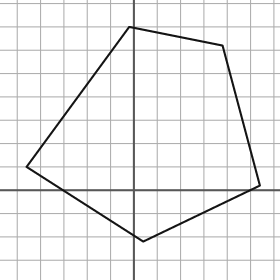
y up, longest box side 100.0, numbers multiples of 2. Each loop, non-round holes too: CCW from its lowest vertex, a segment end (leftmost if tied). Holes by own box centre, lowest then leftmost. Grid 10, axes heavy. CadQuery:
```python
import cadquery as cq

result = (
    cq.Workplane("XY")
    .moveTo(4.0, -22.0)
    .lineTo(54.0, 2.0)
    .lineTo(38.0, 62.0)
    .lineTo(-2.0, 70.0)
    .lineTo(-46.0, 10.0)
    .close()
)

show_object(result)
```